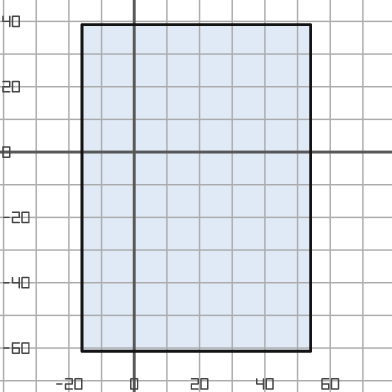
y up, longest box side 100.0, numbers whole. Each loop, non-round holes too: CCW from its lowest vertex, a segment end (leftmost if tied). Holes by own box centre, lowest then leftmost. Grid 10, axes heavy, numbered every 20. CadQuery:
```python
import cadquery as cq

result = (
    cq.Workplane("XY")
    .moveTo(-16.0, -61.0)
    .lineTo(54.0, -61.0)
    .lineTo(54.0, 39.0)
    .lineTo(-16.0, 39.0)
    .close()
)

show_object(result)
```